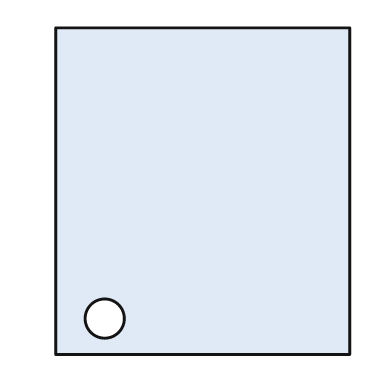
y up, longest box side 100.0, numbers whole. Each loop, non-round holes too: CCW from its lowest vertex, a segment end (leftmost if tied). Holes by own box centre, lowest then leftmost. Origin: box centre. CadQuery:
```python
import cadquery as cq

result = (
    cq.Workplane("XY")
    .moveTo(-45.0, -50.0)
    .lineTo(45.0, -50.0)
    .lineTo(45.0, 50.0)
    .lineTo(-45.0, 50.0)
    .close()
    .moveTo(-30.0, -39.0)
    .circle(6.0)
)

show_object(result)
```